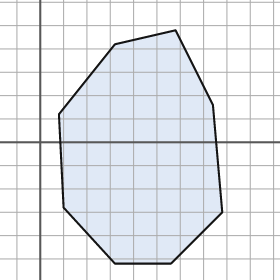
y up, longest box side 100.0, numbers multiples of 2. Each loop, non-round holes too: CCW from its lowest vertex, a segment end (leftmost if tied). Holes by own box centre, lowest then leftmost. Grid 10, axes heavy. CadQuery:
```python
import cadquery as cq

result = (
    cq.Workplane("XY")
    .moveTo(32.0, -52.0)
    .lineTo(56.0, -52.0)
    .lineTo(78.0, -30.0)
    .lineTo(74.0, 16.0)
    .lineTo(58.0, 48.0)
    .lineTo(32.0, 42.0)
    .lineTo(8.0, 12.0)
    .lineTo(10.0, -28.0)
    .close()
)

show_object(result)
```